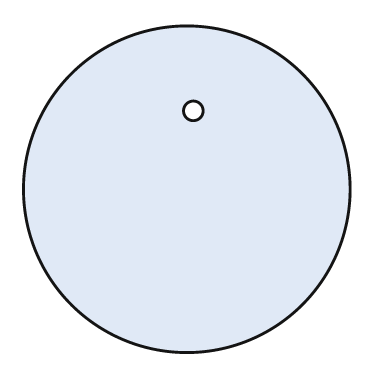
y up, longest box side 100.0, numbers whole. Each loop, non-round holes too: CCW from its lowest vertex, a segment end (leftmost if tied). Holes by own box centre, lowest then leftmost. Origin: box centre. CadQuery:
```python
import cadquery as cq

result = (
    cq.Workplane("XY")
    .moveTo(0.0, 0.0)
    .circle(50.0)
    .moveTo(2.0, 24.0)
    .circle(3.0)
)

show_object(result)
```